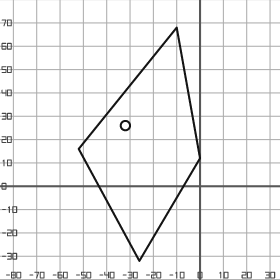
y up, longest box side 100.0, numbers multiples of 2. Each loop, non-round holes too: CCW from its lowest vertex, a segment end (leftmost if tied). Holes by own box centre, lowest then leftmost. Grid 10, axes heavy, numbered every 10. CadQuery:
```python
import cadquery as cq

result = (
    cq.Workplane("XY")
    .moveTo(-26.0, -32.0)
    .lineTo(0.0, 12.0)
    .lineTo(-10.0, 68.0)
    .lineTo(-52.0, 16.0)
    .close()
    .moveTo(-32.0, 26.0)
    .circle(2.0)
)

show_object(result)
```